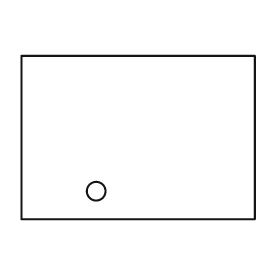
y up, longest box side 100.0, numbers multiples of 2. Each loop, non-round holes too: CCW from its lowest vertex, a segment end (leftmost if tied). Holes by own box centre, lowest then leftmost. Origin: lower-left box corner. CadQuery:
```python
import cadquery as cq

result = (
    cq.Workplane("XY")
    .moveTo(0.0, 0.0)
    .lineTo(100.0, 0.0)
    .lineTo(100.0, 70.0)
    .lineTo(0.0, 70.0)
    .close()
    .moveTo(32.0, 12.0)
    .circle(4.0)
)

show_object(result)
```